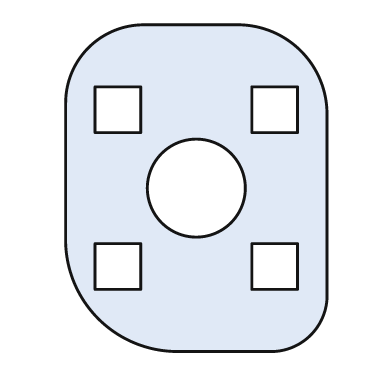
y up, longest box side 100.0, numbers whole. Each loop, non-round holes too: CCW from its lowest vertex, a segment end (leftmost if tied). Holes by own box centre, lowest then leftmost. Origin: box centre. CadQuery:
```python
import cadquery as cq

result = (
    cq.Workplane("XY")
    .moveTo(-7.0, -50.0)
    .lineTo(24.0, -50.0)
    .threePointArc((35.0, -45.0), (40.0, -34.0))
    .lineTo(40.0, 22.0)
    .threePointArc((32.0, 42.0), (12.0, 50.0))
    .lineTo(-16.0, 50.0)
    .threePointArc((-33.0, 43.0), (-40.0, 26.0))
    .lineTo(-40.0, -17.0)
    .threePointArc((-30.0, -40.0), (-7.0, -50.0))
    .close()
    .moveTo(-31.0, -31.0)
    .lineTo(-17.0, -31.0)
    .lineTo(-17.0, -17.0)
    .lineTo(-31.0, -17.0)
    .close()
    .moveTo(17.0, -31.0)
    .lineTo(31.0, -31.0)
    .lineTo(31.0, -17.0)
    .lineTo(17.0, -17.0)
    .close()
    .moveTo(0.0, 0.0)
    .circle(15.0)
    .moveTo(-31.0, 17.0)
    .lineTo(-17.0, 17.0)
    .lineTo(-17.0, 31.0)
    .lineTo(-31.0, 31.0)
    .close()
    .moveTo(17.0, 17.0)
    .lineTo(31.0, 17.0)
    .lineTo(31.0, 31.0)
    .lineTo(17.0, 31.0)
    .close()
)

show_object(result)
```